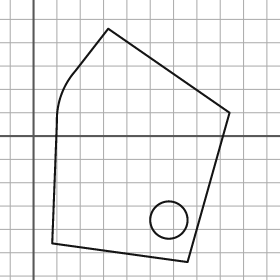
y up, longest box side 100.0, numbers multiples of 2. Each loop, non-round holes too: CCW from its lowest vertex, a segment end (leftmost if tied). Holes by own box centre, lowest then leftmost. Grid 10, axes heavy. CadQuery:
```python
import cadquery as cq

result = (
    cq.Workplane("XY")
    .moveTo(66.0, -54.0)
    .lineTo(84.0, 10.0)
    .lineTo(32.0, 46.0)
    .lineTo(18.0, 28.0)
    .threePointArc((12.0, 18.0), (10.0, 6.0))
    .lineTo(8.0, -46.0)
    .close()
    .moveTo(58.0, -36.0)
    .circle(8.0)
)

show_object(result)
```